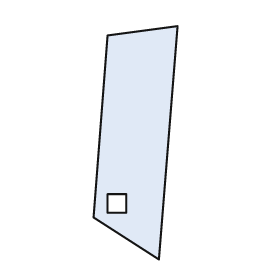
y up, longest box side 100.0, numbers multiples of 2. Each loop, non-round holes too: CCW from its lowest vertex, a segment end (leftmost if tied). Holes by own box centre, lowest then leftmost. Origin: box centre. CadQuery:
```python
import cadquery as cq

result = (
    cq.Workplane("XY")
    .moveTo(10.0, -50.0)
    .lineTo(18.0, 50.0)
    .lineTo(-12.0, 46.0)
    .lineTo(-18.0, -32.0)
    .close()
    .moveTo(-12.0, -30.0)
    .lineTo(-4.0, -30.0)
    .lineTo(-4.0, -22.0)
    .lineTo(-12.0, -22.0)
    .close()
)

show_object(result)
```